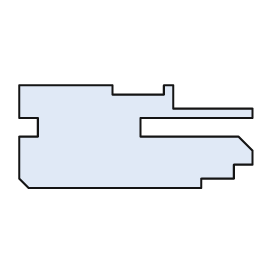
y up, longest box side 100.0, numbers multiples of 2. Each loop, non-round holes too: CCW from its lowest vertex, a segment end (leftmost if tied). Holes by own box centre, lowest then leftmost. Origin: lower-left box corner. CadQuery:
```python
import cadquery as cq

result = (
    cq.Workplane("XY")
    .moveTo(4.0, 0.0)
    .lineTo(78.0, 0.0)
    .lineTo(78.0, 4.0)
    .lineTo(92.0, 4.0)
    .lineTo(92.0, 10.0)
    .lineTo(100.0, 10.0)
    .lineTo(100.0, 16.0)
    .lineTo(94.0, 22.0)
    .lineTo(52.0, 22.0)
    .lineTo(52.0, 30.0)
    .lineTo(100.0, 30.0)
    .lineTo(100.0, 34.0)
    .lineTo(66.0, 34.0)
    .lineTo(66.0, 44.0)
    .lineTo(62.0, 44.0)
    .lineTo(62.0, 40.0)
    .lineTo(40.0, 40.0)
    .lineTo(40.0, 44.0)
    .lineTo(0.0, 44.0)
    .lineTo(0.0, 30.0)
    .lineTo(8.0, 30.0)
    .lineTo(8.0, 22.0)
    .lineTo(0.0, 22.0)
    .lineTo(0.0, 4.0)
    .close()
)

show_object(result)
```